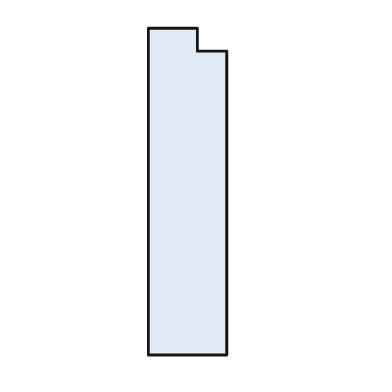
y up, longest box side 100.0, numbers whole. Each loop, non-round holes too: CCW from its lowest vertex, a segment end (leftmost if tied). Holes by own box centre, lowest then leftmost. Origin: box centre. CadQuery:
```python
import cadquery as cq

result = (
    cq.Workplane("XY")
    .moveTo(-12.0, -50.0)
    .lineTo(12.0, -50.0)
    .lineTo(12.0, 43.0)
    .lineTo(3.0, 43.0)
    .lineTo(3.0, 50.0)
    .lineTo(-12.0, 50.0)
    .close()
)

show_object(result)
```